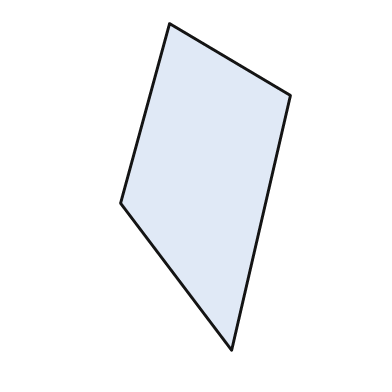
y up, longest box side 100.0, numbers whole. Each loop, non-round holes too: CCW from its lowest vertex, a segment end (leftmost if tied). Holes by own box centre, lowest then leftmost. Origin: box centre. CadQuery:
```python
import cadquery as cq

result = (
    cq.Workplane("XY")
    .moveTo(8.0, -50.0)
    .lineTo(26.0, 28.0)
    .lineTo(-11.0, 50.0)
    .lineTo(-26.0, -5.0)
    .close()
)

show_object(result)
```